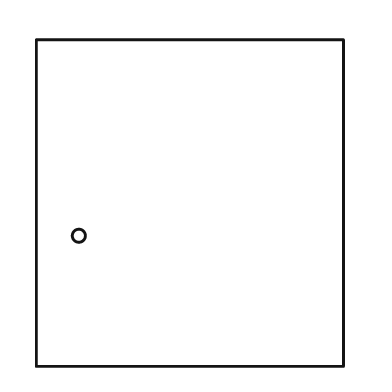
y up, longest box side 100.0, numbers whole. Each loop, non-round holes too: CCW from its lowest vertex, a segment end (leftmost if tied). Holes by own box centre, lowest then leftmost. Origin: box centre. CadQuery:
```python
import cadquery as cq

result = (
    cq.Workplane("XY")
    .moveTo(-47.0, -50.0)
    .lineTo(47.0, -50.0)
    .lineTo(47.0, 50.0)
    .lineTo(-47.0, 50.0)
    .close()
    .moveTo(-34.0, -10.0)
    .circle(2.0)
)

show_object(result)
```